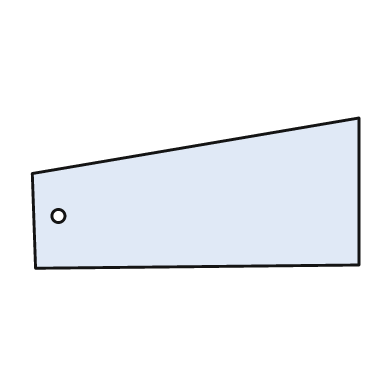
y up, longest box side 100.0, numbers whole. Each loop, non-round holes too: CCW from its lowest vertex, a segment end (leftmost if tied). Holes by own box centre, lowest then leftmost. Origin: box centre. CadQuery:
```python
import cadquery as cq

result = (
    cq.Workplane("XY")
    .moveTo(-49.0, -23.0)
    .lineTo(50.0, -22.0)
    .lineTo(50.0, 23.0)
    .lineTo(-50.0, 6.0)
    .close()
    .moveTo(-42.0, -7.0)
    .circle(2.0)
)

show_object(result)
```